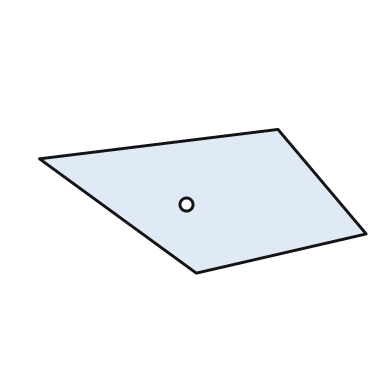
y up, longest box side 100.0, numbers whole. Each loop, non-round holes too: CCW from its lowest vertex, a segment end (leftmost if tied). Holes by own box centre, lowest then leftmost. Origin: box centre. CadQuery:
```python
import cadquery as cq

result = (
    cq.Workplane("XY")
    .moveTo(-2.0, -22.0)
    .lineTo(50.0, -10.0)
    .lineTo(23.0, 22.0)
    .lineTo(-50.0, 13.0)
    .close()
    .moveTo(-5.0, -1.0)
    .circle(2.0)
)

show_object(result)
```